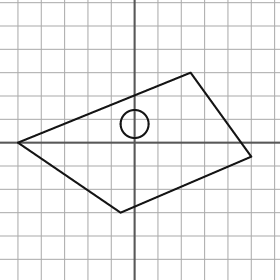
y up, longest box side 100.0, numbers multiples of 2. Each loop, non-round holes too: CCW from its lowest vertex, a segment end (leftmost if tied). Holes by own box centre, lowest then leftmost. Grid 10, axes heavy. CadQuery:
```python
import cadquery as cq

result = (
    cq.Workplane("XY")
    .moveTo(-6.0, -30.0)
    .lineTo(50.0, -6.0)
    .lineTo(24.0, 30.0)
    .lineTo(-50.0, 0.0)
    .close()
    .moveTo(0.0, 8.0)
    .circle(6.0)
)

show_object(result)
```